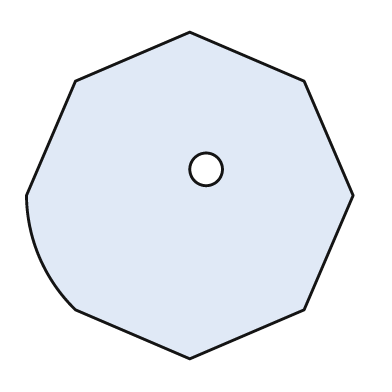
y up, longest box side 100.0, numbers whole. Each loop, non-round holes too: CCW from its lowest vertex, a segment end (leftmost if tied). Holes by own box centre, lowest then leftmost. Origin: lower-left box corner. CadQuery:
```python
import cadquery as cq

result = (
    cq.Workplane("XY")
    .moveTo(50.0, 0.0)
    .lineTo(85.0, 15.0)
    .lineTo(100.0, 50.0)
    .lineTo(85.0, 85.0)
    .lineTo(50.0, 100.0)
    .lineTo(15.0, 85.0)
    .lineTo(0.0, 50.0)
    .threePointArc((4.0, 31.0), (15.0, 15.0))
    .close()
    .moveTo(55.0, 58.0)
    .circle(5.0)
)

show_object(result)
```